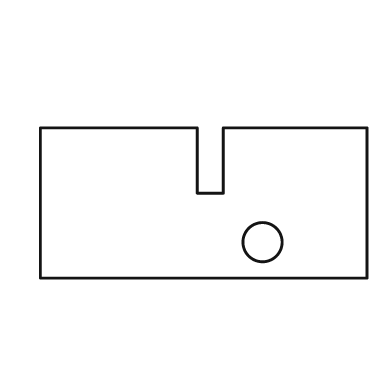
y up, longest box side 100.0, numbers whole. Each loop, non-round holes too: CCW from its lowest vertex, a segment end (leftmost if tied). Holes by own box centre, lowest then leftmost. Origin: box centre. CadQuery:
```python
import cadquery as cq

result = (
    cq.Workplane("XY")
    .moveTo(-50.0, -23.0)
    .lineTo(50.0, -23.0)
    .lineTo(50.0, 23.0)
    .lineTo(6.0, 23.0)
    .lineTo(6.0, 3.0)
    .lineTo(-2.0, 3.0)
    .lineTo(-2.0, 23.0)
    .lineTo(-50.0, 23.0)
    .close()
    .moveTo(18.0, -12.0)
    .circle(6.0)
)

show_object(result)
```